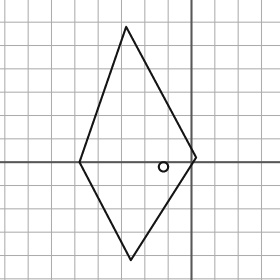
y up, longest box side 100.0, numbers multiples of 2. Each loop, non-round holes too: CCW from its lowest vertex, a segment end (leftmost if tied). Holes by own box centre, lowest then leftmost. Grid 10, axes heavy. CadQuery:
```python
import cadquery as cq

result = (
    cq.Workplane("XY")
    .moveTo(-26.0, -42.0)
    .lineTo(2.0, 2.0)
    .lineTo(-28.0, 58.0)
    .lineTo(-48.0, 0.0)
    .close()
    .moveTo(-12.0, -2.0)
    .circle(2.0)
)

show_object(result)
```